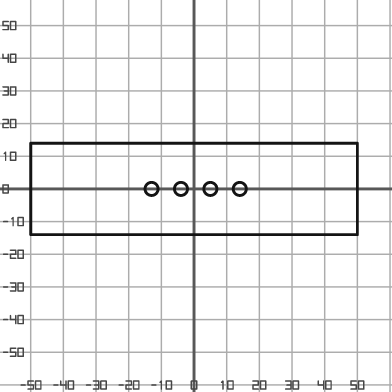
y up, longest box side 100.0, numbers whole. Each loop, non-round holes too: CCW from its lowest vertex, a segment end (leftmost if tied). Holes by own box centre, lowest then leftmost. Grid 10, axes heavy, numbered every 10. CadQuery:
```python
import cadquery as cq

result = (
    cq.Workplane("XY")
    .moveTo(-50.0, -14.0)
    .lineTo(50.0, -14.0)
    .lineTo(50.0, 14.0)
    .lineTo(-50.0, 14.0)
    .close()
    .moveTo(-13.0, 0.0)
    .circle(2.0)
    .moveTo(-4.0, 0.0)
    .circle(2.0)
    .moveTo(5.0, 0.0)
    .circle(2.0)
    .moveTo(14.0, 0.0)
    .circle(2.0)
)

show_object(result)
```